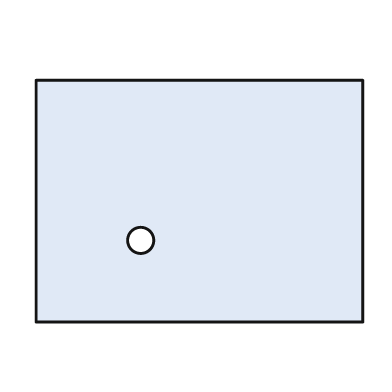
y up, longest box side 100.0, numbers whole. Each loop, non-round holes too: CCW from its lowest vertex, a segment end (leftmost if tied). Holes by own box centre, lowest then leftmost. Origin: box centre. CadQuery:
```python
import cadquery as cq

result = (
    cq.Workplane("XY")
    .moveTo(-50.0, -37.0)
    .lineTo(50.0, -37.0)
    .lineTo(50.0, 37.0)
    .lineTo(-50.0, 37.0)
    .close()
    .moveTo(-18.0, -12.0)
    .circle(4.0)
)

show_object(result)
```